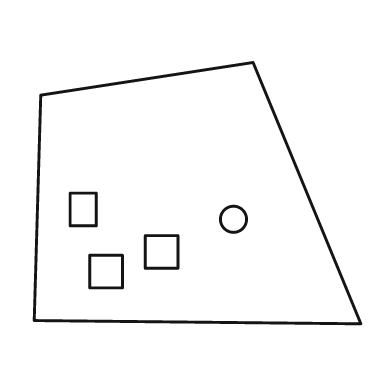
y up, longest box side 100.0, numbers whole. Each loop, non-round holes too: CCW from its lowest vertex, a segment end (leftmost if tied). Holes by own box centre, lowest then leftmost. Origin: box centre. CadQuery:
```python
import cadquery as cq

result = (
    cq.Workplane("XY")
    .moveTo(50.0, -40.0)
    .lineTo(17.0, 40.0)
    .lineTo(-48.0, 30.0)
    .lineTo(-50.0, -39.0)
    .close()
    .moveTo(-33.0, -29.0)
    .lineTo(-23.0, -29.0)
    .lineTo(-23.0, -19.0)
    .lineTo(-33.0, -19.0)
    .close()
    .moveTo(-16.0, -23.0)
    .lineTo(-6.0, -23.0)
    .lineTo(-6.0, -13.0)
    .lineTo(-16.0, -13.0)
    .close()
    .moveTo(11.0, -8.0)
    .circle(4.0)
    .moveTo(-39.0, -10.0)
    .lineTo(-31.0, -10.0)
    .lineTo(-31.0, 0.0)
    .lineTo(-39.0, 0.0)
    .close()
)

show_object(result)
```